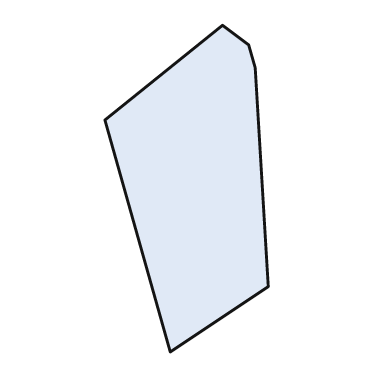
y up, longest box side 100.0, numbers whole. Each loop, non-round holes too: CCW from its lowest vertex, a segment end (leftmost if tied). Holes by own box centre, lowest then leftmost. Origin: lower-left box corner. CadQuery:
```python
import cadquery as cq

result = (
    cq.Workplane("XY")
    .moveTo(20.0, 0.0)
    .lineTo(50.0, 20.0)
    .lineTo(46.0, 87.0)
    .lineTo(44.0, 94.0)
    .lineTo(36.0, 100.0)
    .lineTo(0.0, 71.0)
    .close()
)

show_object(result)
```